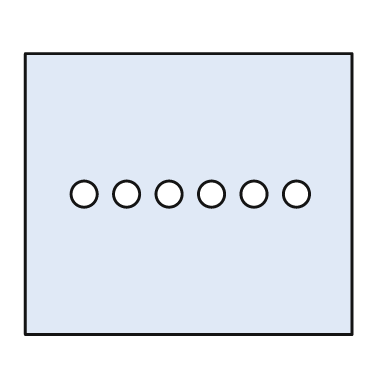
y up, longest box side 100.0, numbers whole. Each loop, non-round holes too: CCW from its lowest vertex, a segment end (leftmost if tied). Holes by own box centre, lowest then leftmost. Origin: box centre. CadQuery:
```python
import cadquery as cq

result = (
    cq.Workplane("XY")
    .moveTo(-50.0, -43.0)
    .lineTo(50.0, -43.0)
    .lineTo(50.0, 43.0)
    .lineTo(-50.0, 43.0)
    .close()
    .moveTo(-32.0, 0.0)
    .circle(4.0)
    .moveTo(-19.0, 0.0)
    .circle(4.0)
    .moveTo(-6.0, 0.0)
    .circle(4.0)
    .moveTo(7.0, 0.0)
    .circle(4.0)
    .moveTo(20.0, 0.0)
    .circle(4.0)
    .moveTo(33.0, 0.0)
    .circle(4.0)
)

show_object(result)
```